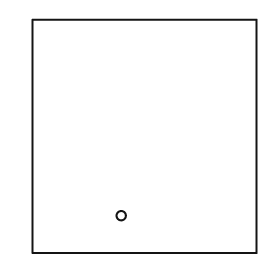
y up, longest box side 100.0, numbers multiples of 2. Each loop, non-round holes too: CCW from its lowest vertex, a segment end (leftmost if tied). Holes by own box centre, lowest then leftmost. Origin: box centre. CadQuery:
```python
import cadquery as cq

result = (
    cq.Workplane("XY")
    .moveTo(-48.0, -50.0)
    .lineTo(48.0, -50.0)
    .lineTo(48.0, 50.0)
    .lineTo(-48.0, 50.0)
    .close()
    .moveTo(-10.0, -34.0)
    .circle(2.0)
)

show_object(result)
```